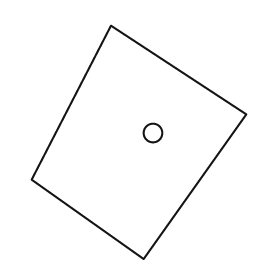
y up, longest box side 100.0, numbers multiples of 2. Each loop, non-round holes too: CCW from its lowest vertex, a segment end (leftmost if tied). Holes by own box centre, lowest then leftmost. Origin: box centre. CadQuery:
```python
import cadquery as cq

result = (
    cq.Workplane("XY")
    .moveTo(2.0, -50.0)
    .lineTo(46.0, 12.0)
    .lineTo(-12.0, 50.0)
    .lineTo(-46.0, -16.0)
    .close()
    .moveTo(6.0, 4.0)
    .circle(4.0)
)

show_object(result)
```